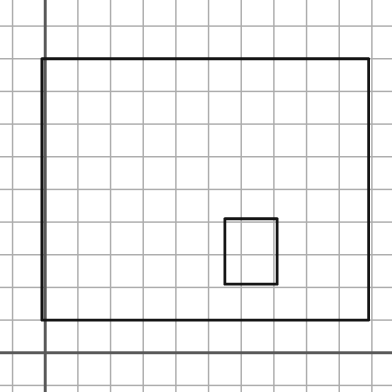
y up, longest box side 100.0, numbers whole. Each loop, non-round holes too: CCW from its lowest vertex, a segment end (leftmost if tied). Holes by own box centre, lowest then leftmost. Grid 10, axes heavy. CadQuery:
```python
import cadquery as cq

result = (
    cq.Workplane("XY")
    .moveTo(-1.0, 10.0)
    .lineTo(99.0, 10.0)
    .lineTo(99.0, 90.0)
    .lineTo(-1.0, 90.0)
    .close()
    .moveTo(55.0, 21.0)
    .lineTo(71.0, 21.0)
    .lineTo(71.0, 41.0)
    .lineTo(55.0, 41.0)
    .close()
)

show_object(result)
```